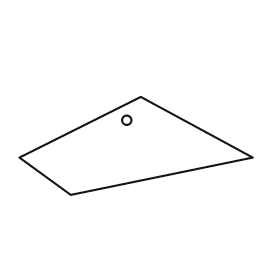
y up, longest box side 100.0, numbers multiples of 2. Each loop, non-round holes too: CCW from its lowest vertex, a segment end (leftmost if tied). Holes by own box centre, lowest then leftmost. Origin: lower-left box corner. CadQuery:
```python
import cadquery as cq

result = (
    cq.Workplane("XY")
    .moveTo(22.0, 0.0)
    .lineTo(100.0, 16.0)
    .lineTo(52.0, 42.0)
    .lineTo(0.0, 16.0)
    .close()
    .moveTo(46.0, 32.0)
    .circle(2.0)
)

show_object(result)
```